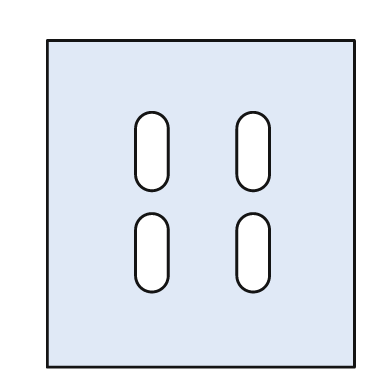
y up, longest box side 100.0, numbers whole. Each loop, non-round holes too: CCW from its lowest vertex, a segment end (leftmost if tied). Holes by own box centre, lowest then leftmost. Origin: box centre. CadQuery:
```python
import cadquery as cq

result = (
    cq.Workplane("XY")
    .moveTo(-47.0, -50.0)
    .lineTo(47.0, -50.0)
    .lineTo(47.0, 50.0)
    .lineTo(-47.0, 50.0)
    .close()
    .moveTo(-20.0, -22.0)
    .threePointArc((-15.0, -27.0), (-10.0, -22.0))
    .lineTo(-10.0, -8.0)
    .threePointArc((-15.0, -3.0), (-20.0, -8.0))
    .close()
    .moveTo(11.0, -22.0)
    .threePointArc((16.0, -27.0), (21.0, -22.0))
    .lineTo(21.0, -8.0)
    .threePointArc((16.0, -3.0), (11.0, -8.0))
    .close()
    .moveTo(-20.0, 9.0)
    .threePointArc((-15.0, 4.0), (-10.0, 9.0))
    .lineTo(-10.0, 23.0)
    .threePointArc((-15.0, 28.0), (-20.0, 23.0))
    .close()
    .moveTo(11.0, 9.0)
    .threePointArc((16.0, 4.0), (21.0, 9.0))
    .lineTo(21.0, 23.0)
    .threePointArc((16.0, 28.0), (11.0, 23.0))
    .close()
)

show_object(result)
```